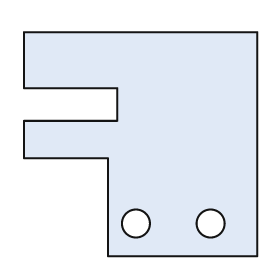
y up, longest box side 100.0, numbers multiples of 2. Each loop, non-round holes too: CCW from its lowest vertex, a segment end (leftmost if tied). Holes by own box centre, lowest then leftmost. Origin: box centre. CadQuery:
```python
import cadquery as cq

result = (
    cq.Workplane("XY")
    .moveTo(-14.0, -48.0)
    .lineTo(50.0, -48.0)
    .lineTo(50.0, 48.0)
    .lineTo(-50.0, 48.0)
    .lineTo(-50.0, 24.0)
    .lineTo(-10.0, 24.0)
    .lineTo(-10.0, 10.0)
    .lineTo(-50.0, 10.0)
    .lineTo(-50.0, -6.0)
    .lineTo(-14.0, -6.0)
    .close()
    .moveTo(-2.0, -34.0)
    .circle(6.0)
    .moveTo(30.0, -34.0)
    .circle(6.0)
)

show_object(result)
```